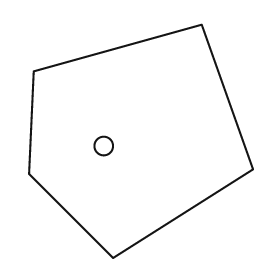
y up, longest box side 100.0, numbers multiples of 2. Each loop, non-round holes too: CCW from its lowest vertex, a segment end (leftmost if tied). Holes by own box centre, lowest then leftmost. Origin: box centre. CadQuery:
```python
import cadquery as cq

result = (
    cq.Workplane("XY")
    .moveTo(-12.0, -50.0)
    .lineTo(48.0, -12.0)
    .lineTo(26.0, 50.0)
    .lineTo(-46.0, 30.0)
    .lineTo(-48.0, -14.0)
    .close()
    .moveTo(-16.0, -2.0)
    .circle(4.0)
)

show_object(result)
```